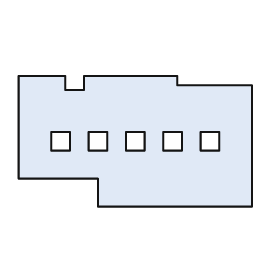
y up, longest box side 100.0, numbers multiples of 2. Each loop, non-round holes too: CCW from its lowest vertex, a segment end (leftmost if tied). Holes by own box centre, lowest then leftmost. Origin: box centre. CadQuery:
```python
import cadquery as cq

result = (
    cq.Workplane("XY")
    .moveTo(-16.0, -28.0)
    .lineTo(50.0, -28.0)
    .lineTo(50.0, 24.0)
    .lineTo(18.0, 24.0)
    .lineTo(18.0, 28.0)
    .lineTo(-22.0, 28.0)
    .lineTo(-22.0, 22.0)
    .lineTo(-30.0, 22.0)
    .lineTo(-30.0, 28.0)
    .lineTo(-50.0, 28.0)
    .lineTo(-50.0, -16.0)
    .lineTo(-16.0, -16.0)
    .close()
    .moveTo(-36.0, -4.0)
    .lineTo(-28.0, -4.0)
    .lineTo(-28.0, 4.0)
    .lineTo(-36.0, 4.0)
    .close()
    .moveTo(-20.0, -4.0)
    .lineTo(-12.0, -4.0)
    .lineTo(-12.0, 4.0)
    .lineTo(-20.0, 4.0)
    .close()
    .moveTo(-4.0, -4.0)
    .lineTo(4.0, -4.0)
    .lineTo(4.0, 4.0)
    .lineTo(-4.0, 4.0)
    .close()
    .moveTo(12.0, -4.0)
    .lineTo(20.0, -4.0)
    .lineTo(20.0, 4.0)
    .lineTo(12.0, 4.0)
    .close()
    .moveTo(28.0, -4.0)
    .lineTo(36.0, -4.0)
    .lineTo(36.0, 4.0)
    .lineTo(28.0, 4.0)
    .close()
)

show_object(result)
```